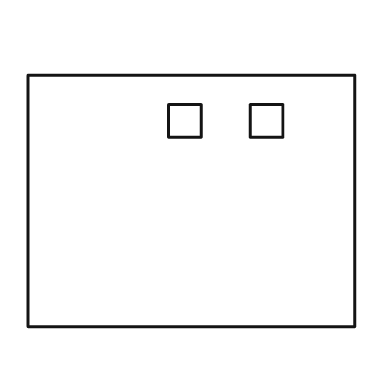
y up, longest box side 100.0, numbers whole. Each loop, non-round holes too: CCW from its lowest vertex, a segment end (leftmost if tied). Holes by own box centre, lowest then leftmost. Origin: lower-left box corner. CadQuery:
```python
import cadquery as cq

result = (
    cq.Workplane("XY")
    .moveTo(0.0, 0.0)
    .lineTo(100.0, 0.0)
    .lineTo(100.0, 77.0)
    .lineTo(0.0, 77.0)
    .close()
    .moveTo(43.0, 58.0)
    .lineTo(53.0, 58.0)
    .lineTo(53.0, 68.0)
    .lineTo(43.0, 68.0)
    .close()
    .moveTo(68.0, 58.0)
    .lineTo(78.0, 58.0)
    .lineTo(78.0, 68.0)
    .lineTo(68.0, 68.0)
    .close()
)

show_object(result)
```